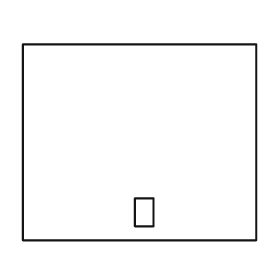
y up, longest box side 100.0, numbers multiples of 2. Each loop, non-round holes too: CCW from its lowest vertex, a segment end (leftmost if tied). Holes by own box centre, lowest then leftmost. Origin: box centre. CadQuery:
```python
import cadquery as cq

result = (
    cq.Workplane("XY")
    .moveTo(-50.0, -42.0)
    .lineTo(50.0, -42.0)
    .lineTo(50.0, 42.0)
    .lineTo(-50.0, 42.0)
    .close()
    .moveTo(-2.0, -36.0)
    .lineTo(6.0, -36.0)
    .lineTo(6.0, -24.0)
    .lineTo(-2.0, -24.0)
    .close()
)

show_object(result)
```